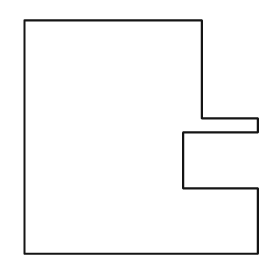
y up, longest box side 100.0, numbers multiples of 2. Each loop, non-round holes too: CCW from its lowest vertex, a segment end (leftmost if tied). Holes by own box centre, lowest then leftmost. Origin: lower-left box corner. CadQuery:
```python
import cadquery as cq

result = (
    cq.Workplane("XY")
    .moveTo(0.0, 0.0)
    .lineTo(100.0, 0.0)
    .lineTo(100.0, 28.0)
    .lineTo(68.0, 28.0)
    .lineTo(68.0, 52.0)
    .lineTo(100.0, 52.0)
    .lineTo(100.0, 58.0)
    .lineTo(76.0, 58.0)
    .lineTo(76.0, 100.0)
    .lineTo(0.0, 100.0)
    .close()
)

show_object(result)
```